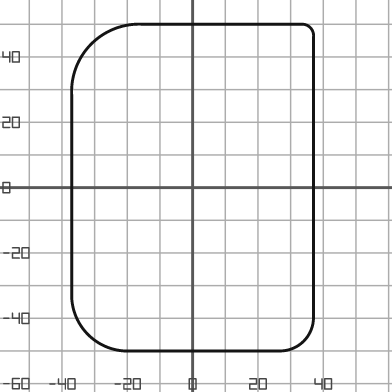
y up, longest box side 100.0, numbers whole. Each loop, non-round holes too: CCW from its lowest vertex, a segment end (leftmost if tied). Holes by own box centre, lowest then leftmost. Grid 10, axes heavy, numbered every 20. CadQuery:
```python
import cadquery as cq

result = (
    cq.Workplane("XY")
    .moveTo(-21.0, -50.0)
    .lineTo(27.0, -50.0)
    .threePointArc((34.0, -47.0), (37.0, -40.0))
    .lineTo(37.0, 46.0)
    .threePointArc((36.0, 49.0), (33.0, 50.0))
    .lineTo(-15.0, 50.0)
    .threePointArc((-31.0, 44.0), (-37.0, 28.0))
    .lineTo(-37.0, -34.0)
    .threePointArc((-32.0, -45.0), (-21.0, -50.0))
    .close()
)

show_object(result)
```